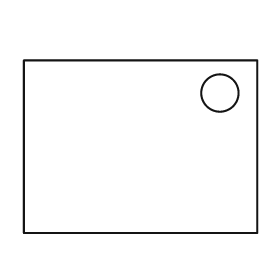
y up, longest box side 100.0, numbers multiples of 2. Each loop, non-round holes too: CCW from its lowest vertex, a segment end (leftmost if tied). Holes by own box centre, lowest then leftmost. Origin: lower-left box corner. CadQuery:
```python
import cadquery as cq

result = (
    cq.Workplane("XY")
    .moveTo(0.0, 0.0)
    .lineTo(100.0, 0.0)
    .lineTo(100.0, 74.0)
    .lineTo(0.0, 74.0)
    .close()
    .moveTo(84.0, 60.0)
    .circle(8.0)
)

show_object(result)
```